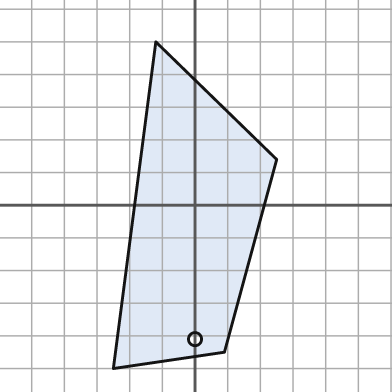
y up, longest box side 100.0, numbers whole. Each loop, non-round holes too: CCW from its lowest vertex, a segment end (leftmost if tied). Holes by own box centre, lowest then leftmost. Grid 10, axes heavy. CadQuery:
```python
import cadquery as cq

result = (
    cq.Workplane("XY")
    .moveTo(-25.0, -50.0)
    .lineTo(9.0, -45.0)
    .lineTo(25.0, 14.0)
    .lineTo(-12.0, 50.0)
    .close()
    .moveTo(0.0, -41.0)
    .circle(2.0)
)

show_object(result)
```